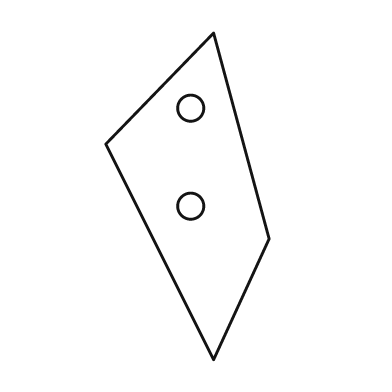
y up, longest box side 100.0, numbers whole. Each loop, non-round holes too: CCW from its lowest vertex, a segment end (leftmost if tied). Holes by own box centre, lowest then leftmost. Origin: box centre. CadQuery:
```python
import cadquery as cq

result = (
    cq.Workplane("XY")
    .moveTo(8.0, -50.0)
    .lineTo(25.0, -13.0)
    .lineTo(8.0, 50.0)
    .lineTo(-25.0, 16.0)
    .close()
    .moveTo(1.0, -3.0)
    .circle(4.0)
    .moveTo(1.0, 27.0)
    .circle(4.0)
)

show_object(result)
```